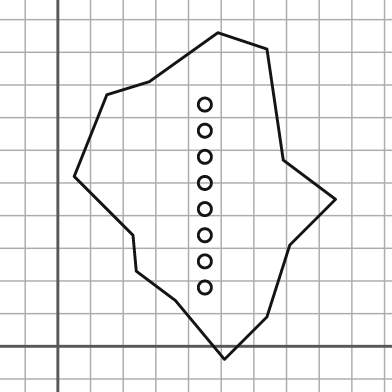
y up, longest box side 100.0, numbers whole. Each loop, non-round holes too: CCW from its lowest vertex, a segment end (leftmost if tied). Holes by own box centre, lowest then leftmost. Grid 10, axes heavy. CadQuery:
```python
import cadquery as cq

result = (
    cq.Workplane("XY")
    .moveTo(51.0, -4.0)
    .lineTo(64.0, 9.0)
    .lineTo(71.0, 31.0)
    .lineTo(85.0, 45.0)
    .lineTo(69.0, 57.0)
    .lineTo(64.0, 91.0)
    .lineTo(49.0, 96.0)
    .lineTo(28.0, 81.0)
    .lineTo(15.0, 77.0)
    .lineTo(5.0, 52.0)
    .lineTo(23.0, 34.0)
    .lineTo(24.0, 23.0)
    .lineTo(36.0, 14.0)
    .close()
    .moveTo(45.0, 18.0)
    .circle(2.0)
    .moveTo(45.0, 26.0)
    .circle(2.0)
    .moveTo(45.0, 34.0)
    .circle(2.0)
    .moveTo(45.0, 42.0)
    .circle(2.0)
    .moveTo(45.0, 50.0)
    .circle(2.0)
    .moveTo(45.0, 58.0)
    .circle(2.0)
    .moveTo(45.0, 66.0)
    .circle(2.0)
    .moveTo(45.0, 74.0)
    .circle(2.0)
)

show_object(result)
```